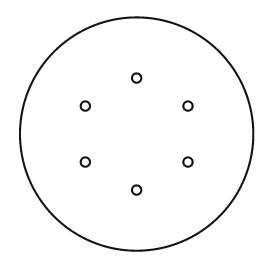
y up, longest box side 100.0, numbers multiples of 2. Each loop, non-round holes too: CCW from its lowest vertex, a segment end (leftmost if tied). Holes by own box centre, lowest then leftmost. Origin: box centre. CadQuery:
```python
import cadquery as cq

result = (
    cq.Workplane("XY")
    .moveTo(0.0, 0.0)
    .circle(50.0)
    .moveTo(0.0, -24.0)
    .circle(2.0)
    .moveTo(-22.0, -12.0)
    .circle(2.0)
    .moveTo(22.0, -12.0)
    .circle(2.0)
    .moveTo(-22.0, 12.0)
    .circle(2.0)
    .moveTo(22.0, 12.0)
    .circle(2.0)
    .moveTo(0.0, 24.0)
    .circle(2.0)
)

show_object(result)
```